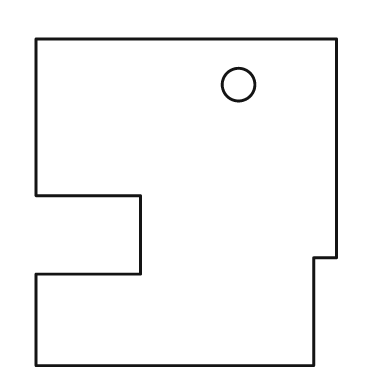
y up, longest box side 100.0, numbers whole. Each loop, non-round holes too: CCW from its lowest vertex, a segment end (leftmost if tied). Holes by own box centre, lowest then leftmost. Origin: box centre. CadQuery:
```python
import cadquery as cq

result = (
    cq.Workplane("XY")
    .moveTo(-46.0, -50.0)
    .lineTo(39.0, -50.0)
    .lineTo(39.0, -17.0)
    .lineTo(46.0, -17.0)
    .lineTo(46.0, 50.0)
    .lineTo(-46.0, 50.0)
    .lineTo(-46.0, 2.0)
    .lineTo(-14.0, 2.0)
    .lineTo(-14.0, -22.0)
    .lineTo(-46.0, -22.0)
    .close()
    .moveTo(16.0, 36.0)
    .circle(5.0)
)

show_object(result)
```